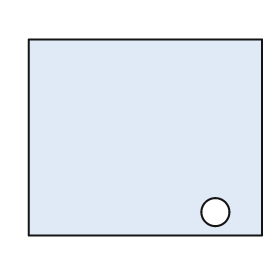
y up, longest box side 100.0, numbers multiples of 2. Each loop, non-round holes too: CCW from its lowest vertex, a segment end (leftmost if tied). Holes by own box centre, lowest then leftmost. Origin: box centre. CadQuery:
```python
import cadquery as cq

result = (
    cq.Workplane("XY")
    .moveTo(-50.0, -42.0)
    .lineTo(50.0, -42.0)
    .lineTo(50.0, 42.0)
    .lineTo(-50.0, 42.0)
    .close()
    .moveTo(30.0, -32.0)
    .circle(6.0)
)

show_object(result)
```